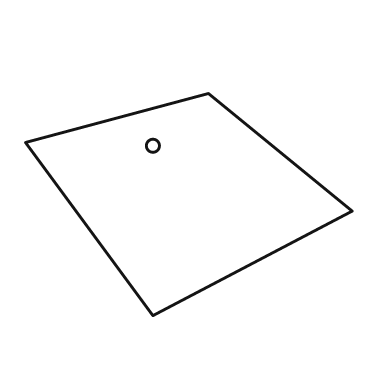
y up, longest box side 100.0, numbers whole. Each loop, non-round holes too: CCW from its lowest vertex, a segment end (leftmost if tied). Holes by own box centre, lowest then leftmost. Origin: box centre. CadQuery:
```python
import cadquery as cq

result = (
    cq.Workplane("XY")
    .moveTo(-11.0, -34.0)
    .lineTo(50.0, -2.0)
    .lineTo(6.0, 34.0)
    .lineTo(-50.0, 19.0)
    .close()
    .moveTo(-11.0, 18.0)
    .circle(2.0)
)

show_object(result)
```